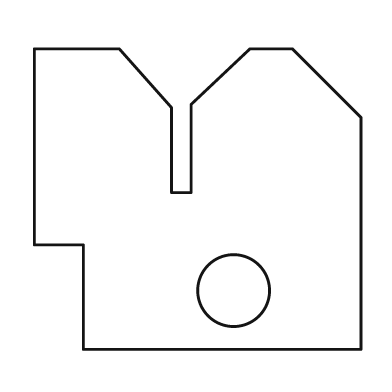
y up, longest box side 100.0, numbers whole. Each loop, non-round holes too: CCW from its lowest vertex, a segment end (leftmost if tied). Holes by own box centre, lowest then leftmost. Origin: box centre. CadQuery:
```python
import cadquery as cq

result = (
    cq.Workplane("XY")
    .moveTo(-35.0, -46.0)
    .lineTo(50.0, -46.0)
    .lineTo(50.0, 25.0)
    .lineTo(29.0, 46.0)
    .lineTo(16.0, 46.0)
    .lineTo(-2.0, 29.0)
    .lineTo(-2.0, 2.0)
    .lineTo(-8.0, 2.0)
    .lineTo(-8.0, 28.0)
    .lineTo(-24.0, 46.0)
    .lineTo(-50.0, 46.0)
    .lineTo(-50.0, -14.0)
    .lineTo(-35.0, -14.0)
    .close()
    .moveTo(11.0, -28.0)
    .circle(11.0)
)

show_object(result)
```